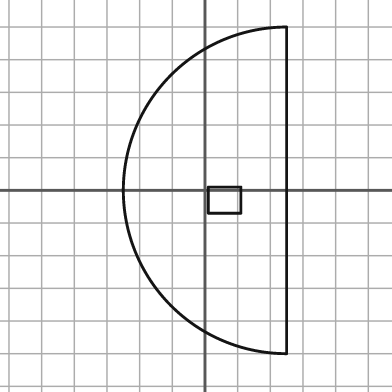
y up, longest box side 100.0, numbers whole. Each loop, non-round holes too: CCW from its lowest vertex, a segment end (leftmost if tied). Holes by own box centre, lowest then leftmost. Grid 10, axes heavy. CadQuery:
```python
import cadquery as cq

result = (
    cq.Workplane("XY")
    .moveTo(25.0, -50.0)
    .lineTo(25.0, 50.0)
    .threePointArc((-25.0, 0.0), (25.0, -50.0))
    .close()
    .moveTo(1.0, -7.0)
    .lineTo(11.0, -7.0)
    .lineTo(11.0, 1.0)
    .lineTo(1.0, 1.0)
    .close()
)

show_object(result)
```